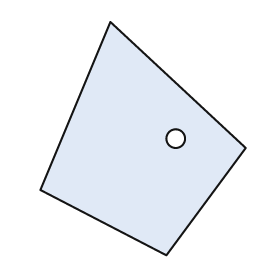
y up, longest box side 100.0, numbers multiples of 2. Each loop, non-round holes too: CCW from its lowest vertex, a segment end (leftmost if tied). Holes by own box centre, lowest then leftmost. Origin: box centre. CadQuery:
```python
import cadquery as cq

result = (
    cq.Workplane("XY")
    .moveTo(10.0, -50.0)
    .lineTo(44.0, -4.0)
    .lineTo(-14.0, 50.0)
    .lineTo(-44.0, -22.0)
    .close()
    .moveTo(14.0, 0.0)
    .circle(4.0)
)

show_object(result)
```